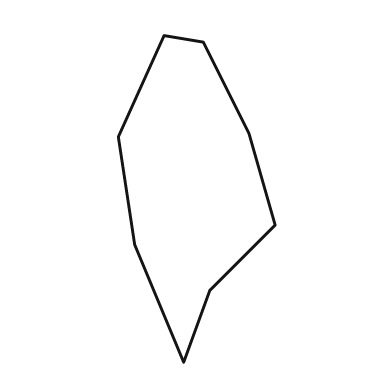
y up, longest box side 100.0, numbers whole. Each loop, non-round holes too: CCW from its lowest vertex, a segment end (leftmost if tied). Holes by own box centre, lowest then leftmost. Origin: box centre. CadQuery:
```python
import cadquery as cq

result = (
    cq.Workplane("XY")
    .moveTo(-4.0, -50.0)
    .lineTo(4.0, -28.0)
    .lineTo(24.0, -8.0)
    .lineTo(16.0, 20.0)
    .lineTo(2.0, 48.0)
    .lineTo(-10.0, 50.0)
    .lineTo(-24.0, 19.0)
    .lineTo(-19.0, -14.0)
    .close()
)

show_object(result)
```